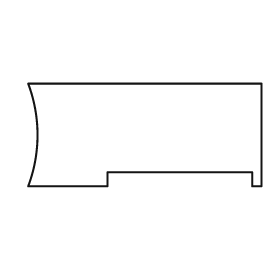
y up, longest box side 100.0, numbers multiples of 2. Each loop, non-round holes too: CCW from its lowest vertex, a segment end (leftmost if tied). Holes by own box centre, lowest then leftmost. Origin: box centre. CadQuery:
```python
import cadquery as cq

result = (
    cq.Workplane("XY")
    .moveTo(-50.0, -22.0)
    .lineTo(-16.0, -22.0)
    .lineTo(-16.0, -16.0)
    .lineTo(46.0, -16.0)
    .lineTo(46.0, -22.0)
    .lineTo(50.0, -22.0)
    .lineTo(50.0, 22.0)
    .lineTo(-50.0, 22.0)
    .threePointArc((-46.0, 0.0), (-50.0, -22.0))
    .close()
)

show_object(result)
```